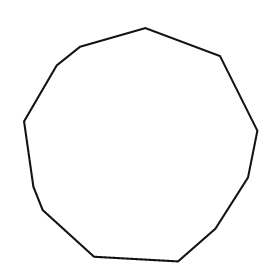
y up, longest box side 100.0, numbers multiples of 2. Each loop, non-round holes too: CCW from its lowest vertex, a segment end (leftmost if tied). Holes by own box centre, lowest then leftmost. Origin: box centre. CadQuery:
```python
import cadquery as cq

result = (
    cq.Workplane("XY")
    .moveTo(16.0, -50.0)
    .lineTo(32.0, -36.0)
    .lineTo(46.0, -14.0)
    .lineTo(50.0, 6.0)
    .lineTo(34.0, 38.0)
    .lineTo(2.0, 50.0)
    .lineTo(-26.0, 42.0)
    .lineTo(-36.0, 34.0)
    .lineTo(-50.0, 10.0)
    .lineTo(-46.0, -18.0)
    .lineTo(-42.0, -28.0)
    .lineTo(-20.0, -48.0)
    .close()
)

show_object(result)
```